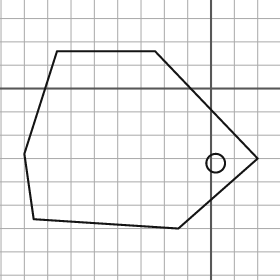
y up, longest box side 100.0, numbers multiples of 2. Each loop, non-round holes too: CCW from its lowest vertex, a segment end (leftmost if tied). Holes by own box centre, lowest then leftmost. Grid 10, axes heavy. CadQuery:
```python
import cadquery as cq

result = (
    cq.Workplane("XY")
    .moveTo(-14.0, -60.0)
    .lineTo(20.0, -30.0)
    .lineTo(-24.0, 16.0)
    .lineTo(-66.0, 16.0)
    .lineTo(-80.0, -28.0)
    .lineTo(-76.0, -56.0)
    .close()
    .moveTo(2.0, -32.0)
    .circle(4.0)
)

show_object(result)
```